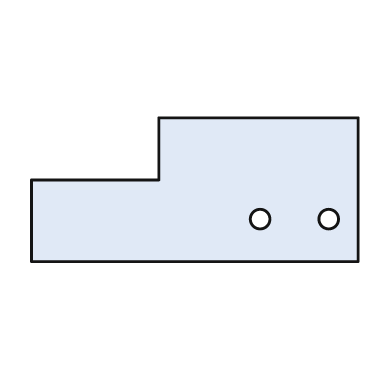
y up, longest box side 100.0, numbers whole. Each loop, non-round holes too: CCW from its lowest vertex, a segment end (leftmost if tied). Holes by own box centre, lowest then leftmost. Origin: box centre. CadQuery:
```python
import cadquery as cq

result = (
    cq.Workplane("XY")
    .moveTo(-50.0, -22.0)
    .lineTo(50.0, -22.0)
    .lineTo(50.0, 22.0)
    .lineTo(-11.0, 22.0)
    .lineTo(-11.0, 3.0)
    .lineTo(-50.0, 3.0)
    .close()
    .moveTo(20.0, -9.0)
    .circle(3.0)
    .moveTo(41.0, -9.0)
    .circle(3.0)
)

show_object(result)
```